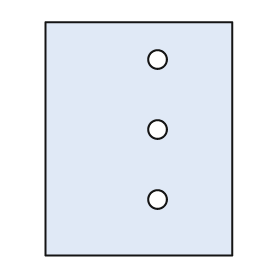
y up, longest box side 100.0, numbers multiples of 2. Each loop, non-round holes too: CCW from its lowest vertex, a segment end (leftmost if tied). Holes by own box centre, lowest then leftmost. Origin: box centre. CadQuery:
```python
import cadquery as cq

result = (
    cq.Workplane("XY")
    .moveTo(-40.0, -50.0)
    .lineTo(40.0, -50.0)
    .lineTo(40.0, 50.0)
    .lineTo(-40.0, 50.0)
    .close()
    .moveTo(8.0, -26.0)
    .circle(4.0)
    .moveTo(8.0, 4.0)
    .circle(4.0)
    .moveTo(8.0, 34.0)
    .circle(4.0)
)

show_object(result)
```